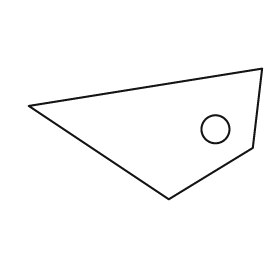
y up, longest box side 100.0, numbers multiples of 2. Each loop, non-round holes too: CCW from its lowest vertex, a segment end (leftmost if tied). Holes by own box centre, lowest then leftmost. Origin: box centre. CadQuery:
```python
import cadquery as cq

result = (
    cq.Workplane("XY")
    .moveTo(10.0, -28.0)
    .lineTo(46.0, -6.0)
    .lineTo(50.0, 28.0)
    .lineTo(-50.0, 12.0)
    .close()
    .moveTo(30.0, 2.0)
    .circle(6.0)
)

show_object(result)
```